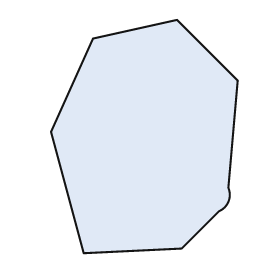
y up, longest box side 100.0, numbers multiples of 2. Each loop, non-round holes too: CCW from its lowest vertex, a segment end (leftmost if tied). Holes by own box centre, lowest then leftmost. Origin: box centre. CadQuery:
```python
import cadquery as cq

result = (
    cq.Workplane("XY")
    .moveTo(-26.0, -50.0)
    .lineTo(16.0, -48.0)
    .lineTo(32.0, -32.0)
    .threePointArc((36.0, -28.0), (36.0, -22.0))
    .lineTo(40.0, 24.0)
    .lineTo(14.0, 50.0)
    .lineTo(-22.0, 42.0)
    .lineTo(-40.0, 2.0)
    .close()
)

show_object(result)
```